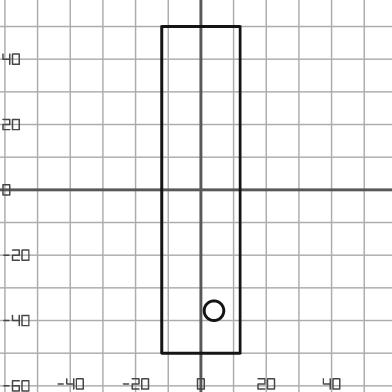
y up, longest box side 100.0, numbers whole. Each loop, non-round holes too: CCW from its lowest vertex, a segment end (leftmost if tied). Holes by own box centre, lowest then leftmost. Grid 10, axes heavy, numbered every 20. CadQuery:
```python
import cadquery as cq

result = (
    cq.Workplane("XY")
    .moveTo(-12.0, -50.0)
    .lineTo(12.0, -50.0)
    .lineTo(12.0, 50.0)
    .lineTo(-12.0, 50.0)
    .close()
    .moveTo(4.0, -37.0)
    .circle(3.0)
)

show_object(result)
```